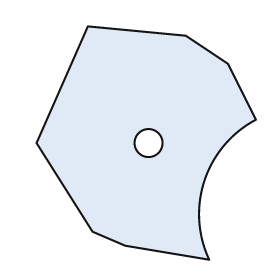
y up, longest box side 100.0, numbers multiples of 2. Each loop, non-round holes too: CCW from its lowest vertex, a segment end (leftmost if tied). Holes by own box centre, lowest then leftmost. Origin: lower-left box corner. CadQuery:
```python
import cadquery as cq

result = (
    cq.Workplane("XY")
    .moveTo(74.0, 0.0)
    .threePointArc((72.0, 34.0), (94.0, 60.0))
    .lineTo(82.0, 84.0)
    .lineTo(64.0, 96.0)
    .lineTo(22.0, 100.0)
    .lineTo(0.0, 50.0)
    .lineTo(24.0, 12.0)
    .lineTo(38.0, 6.0)
    .close()
    .moveTo(48.0, 50.0)
    .circle(6.0)
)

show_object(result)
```